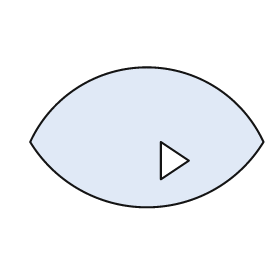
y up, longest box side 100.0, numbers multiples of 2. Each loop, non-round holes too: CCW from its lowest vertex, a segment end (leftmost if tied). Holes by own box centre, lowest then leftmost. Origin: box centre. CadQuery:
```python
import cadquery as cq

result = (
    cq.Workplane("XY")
    .moveTo(-50.0, -2.0)
    .threePointArc((0.0, -30.0), (50.0, -2.0))
    .threePointArc((0.0, 30.0), (-50.0, -2.0))
    .close()
    .moveTo(6.0, -18.0)
    .lineTo(18.0, -10.0)
    .lineTo(6.0, -2.0)
    .close()
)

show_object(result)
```